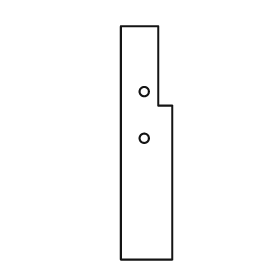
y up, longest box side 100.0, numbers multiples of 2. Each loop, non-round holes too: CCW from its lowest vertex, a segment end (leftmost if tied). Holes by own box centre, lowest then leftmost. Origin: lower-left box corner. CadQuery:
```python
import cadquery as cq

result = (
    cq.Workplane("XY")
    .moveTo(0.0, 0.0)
    .lineTo(22.0, 0.0)
    .lineTo(22.0, 66.0)
    .lineTo(16.0, 66.0)
    .lineTo(16.0, 100.0)
    .lineTo(0.0, 100.0)
    .close()
    .moveTo(10.0, 52.0)
    .circle(2.0)
    .moveTo(10.0, 72.0)
    .circle(2.0)
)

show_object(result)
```